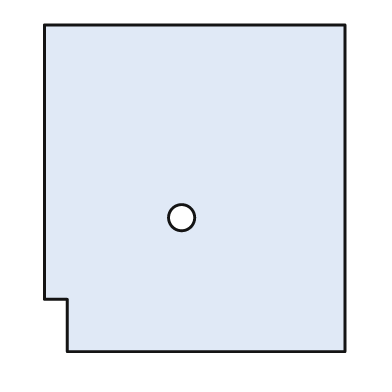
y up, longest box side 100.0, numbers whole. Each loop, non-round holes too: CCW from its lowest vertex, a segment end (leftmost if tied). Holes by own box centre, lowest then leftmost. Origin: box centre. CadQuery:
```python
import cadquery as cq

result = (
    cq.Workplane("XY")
    .moveTo(-39.0, -50.0)
    .lineTo(46.0, -50.0)
    .lineTo(46.0, 50.0)
    .lineTo(-46.0, 50.0)
    .lineTo(-46.0, -34.0)
    .lineTo(-39.0, -34.0)
    .close()
    .moveTo(-4.0, -9.0)
    .circle(4.0)
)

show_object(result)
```